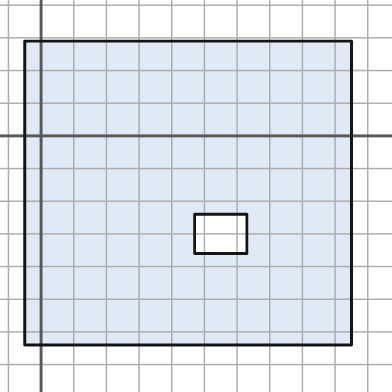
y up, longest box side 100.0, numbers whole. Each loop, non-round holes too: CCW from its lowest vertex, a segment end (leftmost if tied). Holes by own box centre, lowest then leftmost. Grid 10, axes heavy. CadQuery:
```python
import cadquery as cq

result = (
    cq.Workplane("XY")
    .moveTo(-5.0, -64.0)
    .lineTo(95.0, -64.0)
    .lineTo(95.0, 29.0)
    .lineTo(-5.0, 29.0)
    .close()
    .moveTo(47.0, -36.0)
    .lineTo(63.0, -36.0)
    .lineTo(63.0, -24.0)
    .lineTo(47.0, -24.0)
    .close()
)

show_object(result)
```